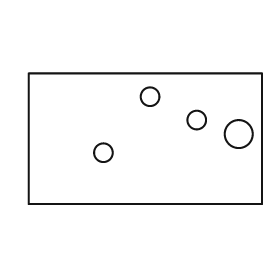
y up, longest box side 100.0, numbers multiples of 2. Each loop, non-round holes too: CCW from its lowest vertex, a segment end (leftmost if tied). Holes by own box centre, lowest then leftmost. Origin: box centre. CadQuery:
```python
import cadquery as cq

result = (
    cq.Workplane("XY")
    .moveTo(-50.0, -28.0)
    .lineTo(50.0, -28.0)
    .lineTo(50.0, 28.0)
    .lineTo(-50.0, 28.0)
    .close()
    .moveTo(-18.0, -6.0)
    .circle(4.0)
    .moveTo(40.0, 2.0)
    .circle(6.0)
    .moveTo(22.0, 8.0)
    .circle(4.0)
    .moveTo(2.0, 18.0)
    .circle(4.0)
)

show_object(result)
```